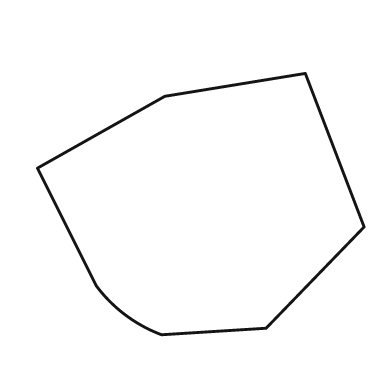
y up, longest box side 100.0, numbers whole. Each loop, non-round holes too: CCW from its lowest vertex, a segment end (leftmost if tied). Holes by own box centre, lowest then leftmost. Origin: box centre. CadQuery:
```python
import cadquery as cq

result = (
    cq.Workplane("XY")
    .moveTo(-12.0, -40.0)
    .lineTo(20.0, -38.0)
    .lineTo(50.0, -7.0)
    .lineTo(32.0, 40.0)
    .lineTo(-11.0, 33.0)
    .lineTo(-50.0, 11.0)
    .lineTo(-32.0, -25.0)
    .threePointArc((-23.0, -34.0), (-12.0, -40.0))
    .close()
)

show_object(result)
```